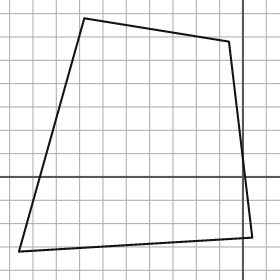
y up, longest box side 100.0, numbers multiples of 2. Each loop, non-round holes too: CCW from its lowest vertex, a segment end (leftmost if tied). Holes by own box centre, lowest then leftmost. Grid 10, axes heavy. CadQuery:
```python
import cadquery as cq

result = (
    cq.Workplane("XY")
    .moveTo(-96.0, -32.0)
    .lineTo(4.0, -26.0)
    .lineTo(-6.0, 58.0)
    .lineTo(-68.0, 68.0)
    .close()
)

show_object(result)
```